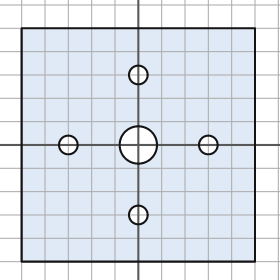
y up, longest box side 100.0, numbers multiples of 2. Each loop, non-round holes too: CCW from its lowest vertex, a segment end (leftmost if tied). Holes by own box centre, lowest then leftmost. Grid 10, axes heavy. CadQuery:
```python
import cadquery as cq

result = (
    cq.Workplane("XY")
    .moveTo(-50.0, -50.0)
    .lineTo(50.0, -50.0)
    .lineTo(50.0, 50.0)
    .lineTo(-50.0, 50.0)
    .close()
    .moveTo(0.0, -30.0)
    .circle(4.0)
    .moveTo(-30.0, 0.0)
    .circle(4.0)
    .moveTo(0.0, 0.0)
    .circle(8.0)
    .moveTo(30.0, 0.0)
    .circle(4.0)
    .moveTo(0.0, 30.0)
    .circle(4.0)
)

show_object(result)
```